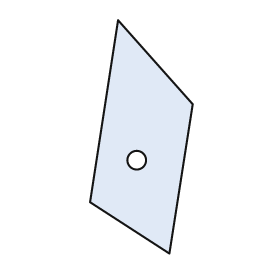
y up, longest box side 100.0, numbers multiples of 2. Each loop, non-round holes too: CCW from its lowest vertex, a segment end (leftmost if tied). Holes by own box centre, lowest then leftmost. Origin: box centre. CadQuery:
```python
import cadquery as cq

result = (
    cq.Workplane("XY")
    .moveTo(12.0, -50.0)
    .lineTo(22.0, 14.0)
    .lineTo(-10.0, 50.0)
    .lineTo(-22.0, -28.0)
    .close()
    .moveTo(-2.0, -10.0)
    .circle(4.0)
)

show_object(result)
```